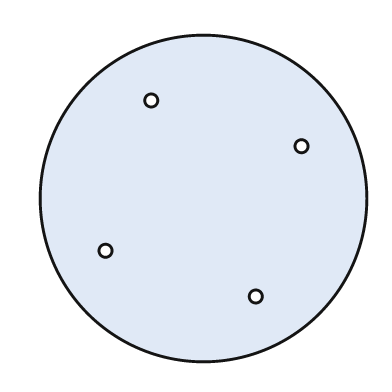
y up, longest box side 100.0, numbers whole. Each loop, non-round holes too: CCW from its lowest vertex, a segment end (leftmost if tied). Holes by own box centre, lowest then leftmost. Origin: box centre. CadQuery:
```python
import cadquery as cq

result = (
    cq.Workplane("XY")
    .moveTo(0.0, 0.0)
    .circle(50.0)
    .moveTo(16.0, -30.0)
    .circle(2.0)
    .moveTo(-30.0, -16.0)
    .circle(2.0)
    .moveTo(30.0, 16.0)
    .circle(2.0)
    .moveTo(-16.0, 30.0)
    .circle(2.0)
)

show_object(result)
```